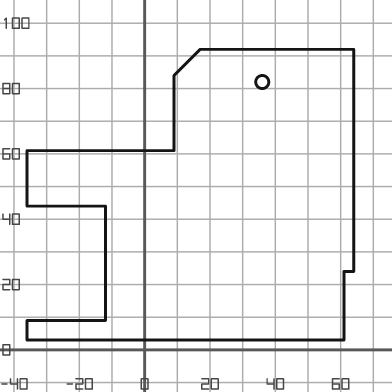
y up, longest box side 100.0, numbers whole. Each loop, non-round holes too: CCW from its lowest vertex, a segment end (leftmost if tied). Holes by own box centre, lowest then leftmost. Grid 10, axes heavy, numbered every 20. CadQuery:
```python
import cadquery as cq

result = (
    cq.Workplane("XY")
    .moveTo(-36.0, 3.0)
    .lineTo(61.0, 3.0)
    .lineTo(61.0, 24.0)
    .lineTo(64.0, 24.0)
    .lineTo(64.0, 92.0)
    .lineTo(17.0, 92.0)
    .lineTo(9.0, 84.0)
    .lineTo(9.0, 61.0)
    .lineTo(-36.0, 61.0)
    .lineTo(-36.0, 44.0)
    .lineTo(-12.0, 44.0)
    .lineTo(-12.0, 9.0)
    .lineTo(-36.0, 9.0)
    .close()
    .moveTo(36.0, 82.0)
    .circle(2.0)
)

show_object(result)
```